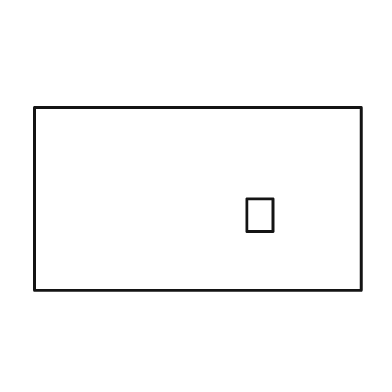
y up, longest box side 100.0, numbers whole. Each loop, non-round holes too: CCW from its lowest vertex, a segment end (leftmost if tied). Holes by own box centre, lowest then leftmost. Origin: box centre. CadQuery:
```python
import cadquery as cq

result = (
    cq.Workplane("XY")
    .moveTo(-50.0, -28.0)
    .lineTo(50.0, -28.0)
    .lineTo(50.0, 28.0)
    .lineTo(-50.0, 28.0)
    .close()
    .moveTo(15.0, -10.0)
    .lineTo(23.0, -10.0)
    .lineTo(23.0, 0.0)
    .lineTo(15.0, 0.0)
    .close()
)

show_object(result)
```